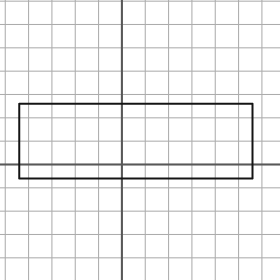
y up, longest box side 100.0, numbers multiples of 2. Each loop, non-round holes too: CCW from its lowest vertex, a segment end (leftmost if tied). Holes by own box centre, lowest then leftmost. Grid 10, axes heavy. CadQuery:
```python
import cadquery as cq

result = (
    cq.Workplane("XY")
    .moveTo(-44.0, -6.0)
    .lineTo(56.0, -6.0)
    .lineTo(56.0, 26.0)
    .lineTo(-44.0, 26.0)
    .close()
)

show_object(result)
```